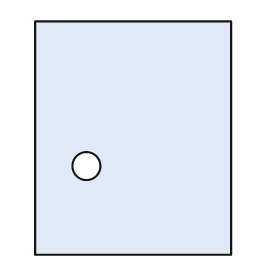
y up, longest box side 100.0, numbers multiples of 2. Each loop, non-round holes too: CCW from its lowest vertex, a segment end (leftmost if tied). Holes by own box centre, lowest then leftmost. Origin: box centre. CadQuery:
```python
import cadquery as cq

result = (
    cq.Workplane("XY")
    .moveTo(-42.0, -50.0)
    .lineTo(42.0, -50.0)
    .lineTo(42.0, 50.0)
    .lineTo(-42.0, 50.0)
    .close()
    .moveTo(-20.0, -12.0)
    .circle(6.0)
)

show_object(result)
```